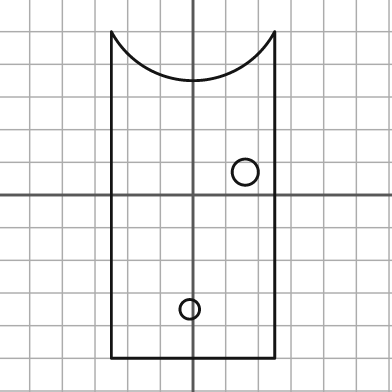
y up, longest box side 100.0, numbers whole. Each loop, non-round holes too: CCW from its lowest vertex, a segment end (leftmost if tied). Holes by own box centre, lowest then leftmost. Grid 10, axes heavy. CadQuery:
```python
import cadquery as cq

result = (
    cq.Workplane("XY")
    .moveTo(-25.0, -50.0)
    .lineTo(25.0, -50.0)
    .lineTo(25.0, 50.0)
    .threePointArc((0.0, 35.0), (-25.0, 50.0))
    .close()
    .moveTo(-1.0, -35.0)
    .circle(3.0)
    .moveTo(16.0, 7.0)
    .circle(4.0)
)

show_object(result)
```